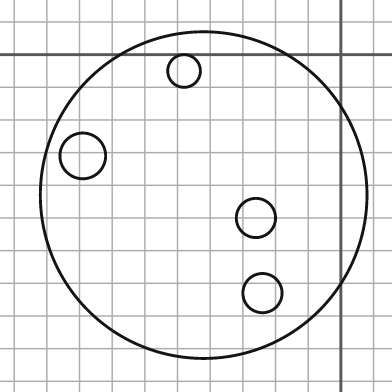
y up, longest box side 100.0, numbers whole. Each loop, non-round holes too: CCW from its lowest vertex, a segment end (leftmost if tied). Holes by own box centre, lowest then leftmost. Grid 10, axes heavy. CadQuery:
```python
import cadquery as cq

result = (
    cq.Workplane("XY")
    .moveTo(-42.0, -43.0)
    .circle(50.0)
    .moveTo(-24.0, -73.0)
    .circle(6.0)
    .moveTo(-26.0, -50.0)
    .circle(6.0)
    .moveTo(-79.0, -31.0)
    .circle(7.0)
    .moveTo(-48.0, -5.0)
    .circle(5.0)
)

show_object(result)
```